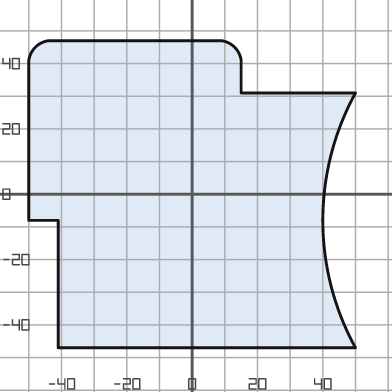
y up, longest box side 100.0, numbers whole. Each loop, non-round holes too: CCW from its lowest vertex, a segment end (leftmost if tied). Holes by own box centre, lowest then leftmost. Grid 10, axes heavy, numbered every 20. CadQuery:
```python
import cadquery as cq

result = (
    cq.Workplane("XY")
    .moveTo(-41.0, -47.0)
    .lineTo(50.0, -47.0)
    .threePointArc((40.0, -8.0), (50.0, 31.0))
    .lineTo(15.0, 31.0)
    .lineTo(15.0, 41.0)
    .threePointArc((13.0, 45.0), (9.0, 47.0))
    .lineTo(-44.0, 47.0)
    .threePointArc((-48.0, 45.0), (-50.0, 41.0))
    .lineTo(-50.0, -8.0)
    .lineTo(-41.0, -8.0)
    .close()
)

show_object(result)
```